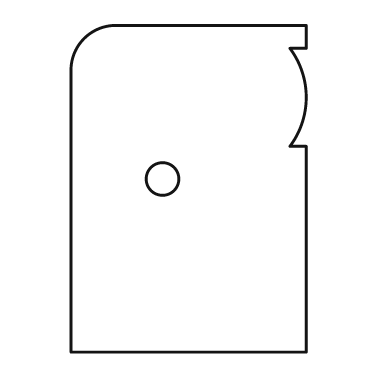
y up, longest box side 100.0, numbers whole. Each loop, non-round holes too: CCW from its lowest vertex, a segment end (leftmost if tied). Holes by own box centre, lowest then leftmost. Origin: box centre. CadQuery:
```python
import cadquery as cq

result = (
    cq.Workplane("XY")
    .moveTo(-36.0, -50.0)
    .lineTo(36.0, -50.0)
    .lineTo(36.0, 13.0)
    .lineTo(31.0, 13.0)
    .threePointArc((36.0, 28.0), (31.0, 43.0))
    .lineTo(36.0, 43.0)
    .lineTo(36.0, 50.0)
    .lineTo(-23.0, 50.0)
    .threePointArc((-32.0, 46.0), (-36.0, 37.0))
    .close()
    .moveTo(-8.0, 3.0)
    .circle(5.0)
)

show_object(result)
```